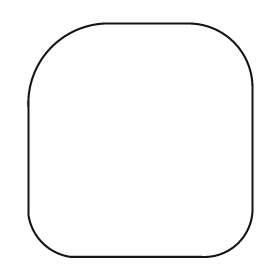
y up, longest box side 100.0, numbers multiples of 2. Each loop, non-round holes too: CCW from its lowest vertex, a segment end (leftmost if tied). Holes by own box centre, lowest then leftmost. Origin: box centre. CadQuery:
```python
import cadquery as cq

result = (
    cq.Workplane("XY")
    .moveTo(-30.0, -50.0)
    .lineTo(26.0, -50.0)
    .threePointArc((42.0, -44.0), (48.0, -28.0))
    .lineTo(48.0, 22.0)
    .threePointArc((40.0, 42.0), (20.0, 50.0))
    .lineTo(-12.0, 50.0)
    .threePointArc((-38.0, 40.0), (-48.0, 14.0))
    .lineTo(-48.0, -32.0)
    .threePointArc((-42.0, -44.0), (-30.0, -50.0))
    .close()
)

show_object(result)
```